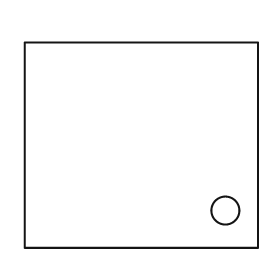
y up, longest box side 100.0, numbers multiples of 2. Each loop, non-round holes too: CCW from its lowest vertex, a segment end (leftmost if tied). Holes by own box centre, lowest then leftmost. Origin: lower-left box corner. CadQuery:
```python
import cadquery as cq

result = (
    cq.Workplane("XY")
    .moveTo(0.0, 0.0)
    .lineTo(100.0, 0.0)
    .lineTo(100.0, 88.0)
    .lineTo(0.0, 88.0)
    .close()
    .moveTo(86.0, 16.0)
    .circle(6.0)
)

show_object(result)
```